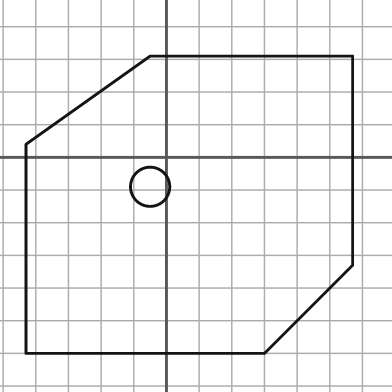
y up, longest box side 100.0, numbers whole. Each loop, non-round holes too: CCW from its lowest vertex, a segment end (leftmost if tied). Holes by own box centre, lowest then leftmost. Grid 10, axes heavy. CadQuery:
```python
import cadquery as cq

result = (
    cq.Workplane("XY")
    .moveTo(-43.0, -60.0)
    .lineTo(30.0, -60.0)
    .lineTo(57.0, -33.0)
    .lineTo(57.0, 31.0)
    .lineTo(-5.0, 31.0)
    .lineTo(-43.0, 4.0)
    .close()
    .moveTo(-5.0, -9.0)
    .circle(6.0)
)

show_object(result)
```